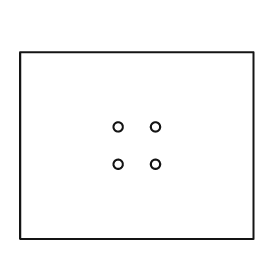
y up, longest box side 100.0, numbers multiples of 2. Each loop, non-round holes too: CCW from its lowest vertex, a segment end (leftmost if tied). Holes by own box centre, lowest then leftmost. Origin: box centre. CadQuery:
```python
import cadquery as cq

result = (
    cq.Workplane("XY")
    .moveTo(-50.0, -40.0)
    .lineTo(50.0, -40.0)
    .lineTo(50.0, 40.0)
    .lineTo(-50.0, 40.0)
    .close()
    .moveTo(-8.0, -8.0)
    .circle(2.0)
    .moveTo(8.0, -8.0)
    .circle(2.0)
    .moveTo(-8.0, 8.0)
    .circle(2.0)
    .moveTo(8.0, 8.0)
    .circle(2.0)
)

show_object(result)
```